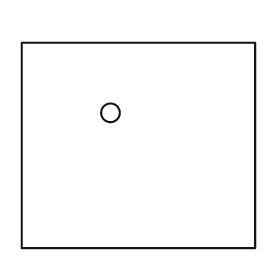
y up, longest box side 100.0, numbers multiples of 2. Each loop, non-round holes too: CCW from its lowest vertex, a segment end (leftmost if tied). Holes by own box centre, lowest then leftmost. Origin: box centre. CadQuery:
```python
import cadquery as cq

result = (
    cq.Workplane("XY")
    .moveTo(-50.0, -44.0)
    .lineTo(50.0, -44.0)
    .lineTo(50.0, 44.0)
    .lineTo(-50.0, 44.0)
    .close()
    .moveTo(-12.0, 14.0)
    .circle(4.0)
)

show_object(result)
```